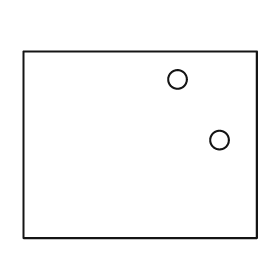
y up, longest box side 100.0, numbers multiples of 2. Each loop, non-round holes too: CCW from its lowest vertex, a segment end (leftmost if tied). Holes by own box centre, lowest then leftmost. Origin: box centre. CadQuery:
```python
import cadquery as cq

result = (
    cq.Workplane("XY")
    .moveTo(-50.0, -40.0)
    .lineTo(50.0, -40.0)
    .lineTo(50.0, 40.0)
    .lineTo(-50.0, 40.0)
    .close()
    .moveTo(34.0, 2.0)
    .circle(4.0)
    .moveTo(16.0, 28.0)
    .circle(4.0)
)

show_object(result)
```